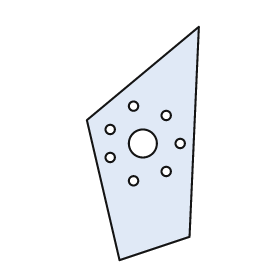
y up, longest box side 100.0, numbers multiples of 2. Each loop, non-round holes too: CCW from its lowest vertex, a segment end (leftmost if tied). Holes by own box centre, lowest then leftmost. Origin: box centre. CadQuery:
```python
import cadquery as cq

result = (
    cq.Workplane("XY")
    .moveTo(-10.0, -50.0)
    .lineTo(20.0, -40.0)
    .lineTo(24.0, 50.0)
    .lineTo(-24.0, 10.0)
    .close()
    .moveTo(-4.0, -16.0)
    .circle(2.0)
    .moveTo(10.0, -12.0)
    .circle(2.0)
    .moveTo(-14.0, -6.0)
    .circle(2.0)
    .moveTo(0.0, 0.0)
    .circle(6.0)
    .moveTo(16.0, 0.0)
    .circle(2.0)
    .moveTo(-14.0, 6.0)
    .circle(2.0)
    .moveTo(10.0, 12.0)
    .circle(2.0)
    .moveTo(-4.0, 16.0)
    .circle(2.0)
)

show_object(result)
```